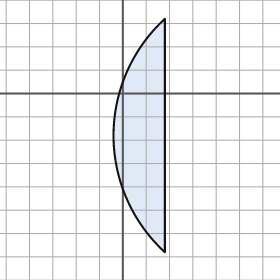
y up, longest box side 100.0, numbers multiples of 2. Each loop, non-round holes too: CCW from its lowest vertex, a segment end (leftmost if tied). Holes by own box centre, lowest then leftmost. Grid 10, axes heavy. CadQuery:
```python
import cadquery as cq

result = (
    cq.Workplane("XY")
    .moveTo(18.0, -68.0)
    .lineTo(18.0, 32.0)
    .threePointArc((-4.0, -18.0), (18.0, -68.0))
    .close()
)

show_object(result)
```